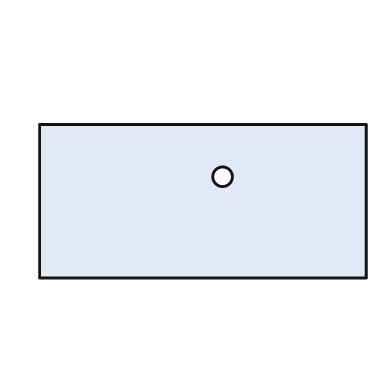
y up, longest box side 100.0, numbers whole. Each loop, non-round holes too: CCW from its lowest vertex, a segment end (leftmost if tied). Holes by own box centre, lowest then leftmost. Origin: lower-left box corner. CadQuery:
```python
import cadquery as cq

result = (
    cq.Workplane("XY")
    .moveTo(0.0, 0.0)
    .lineTo(100.0, 0.0)
    .lineTo(100.0, 47.0)
    .lineTo(0.0, 47.0)
    .close()
    .moveTo(56.0, 31.0)
    .circle(3.0)
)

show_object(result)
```